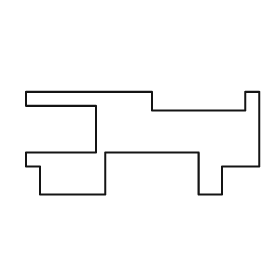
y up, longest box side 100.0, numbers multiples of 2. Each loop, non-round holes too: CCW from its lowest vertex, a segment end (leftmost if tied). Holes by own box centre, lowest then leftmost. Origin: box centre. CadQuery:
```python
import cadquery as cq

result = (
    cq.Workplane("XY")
    .moveTo(-44.0, -22.0)
    .lineTo(-16.0, -22.0)
    .lineTo(-16.0, -4.0)
    .lineTo(24.0, -4.0)
    .lineTo(24.0, -22.0)
    .lineTo(34.0, -22.0)
    .lineTo(34.0, -10.0)
    .lineTo(50.0, -10.0)
    .lineTo(50.0, 22.0)
    .lineTo(44.0, 22.0)
    .lineTo(44.0, 14.0)
    .lineTo(4.0, 14.0)
    .lineTo(4.0, 22.0)
    .lineTo(-50.0, 22.0)
    .lineTo(-50.0, 16.0)
    .lineTo(-20.0, 16.0)
    .lineTo(-20.0, -4.0)
    .lineTo(-50.0, -4.0)
    .lineTo(-50.0, -10.0)
    .lineTo(-44.0, -10.0)
    .close()
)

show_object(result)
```